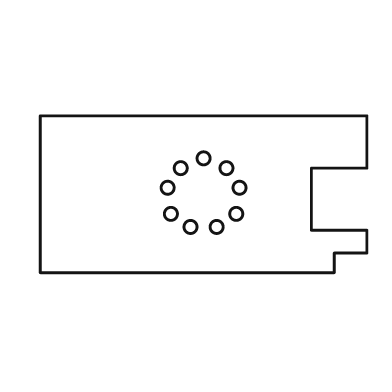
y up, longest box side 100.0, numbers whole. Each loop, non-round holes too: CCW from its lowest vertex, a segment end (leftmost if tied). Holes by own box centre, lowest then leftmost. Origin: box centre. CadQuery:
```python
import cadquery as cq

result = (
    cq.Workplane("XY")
    .moveTo(-50.0, -24.0)
    .lineTo(40.0, -24.0)
    .lineTo(40.0, -18.0)
    .lineTo(50.0, -18.0)
    .lineTo(50.0, -11.0)
    .lineTo(33.0, -11.0)
    .lineTo(33.0, 8.0)
    .lineTo(50.0, 8.0)
    .lineTo(50.0, 24.0)
    .lineTo(-50.0, 24.0)
    .close()
    .moveTo(-4.0, -10.0)
    .circle(2.0)
    .moveTo(4.0, -10.0)
    .circle(2.0)
    .moveTo(-10.0, -6.0)
    .circle(2.0)
    .moveTo(10.0, -6.0)
    .circle(2.0)
    .moveTo(-11.0, 2.0)
    .circle(2.0)
    .moveTo(11.0, 2.0)
    .circle(2.0)
    .moveTo(-7.0, 8.0)
    .circle(2.0)
    .moveTo(7.0, 8.0)
    .circle(2.0)
    .moveTo(0.0, 11.0)
    .circle(2.0)
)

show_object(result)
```